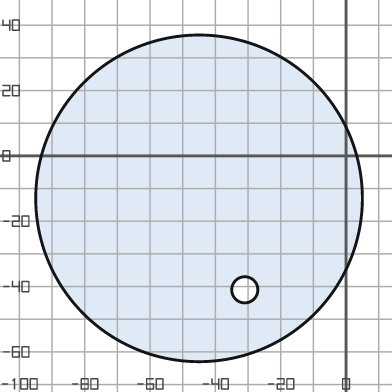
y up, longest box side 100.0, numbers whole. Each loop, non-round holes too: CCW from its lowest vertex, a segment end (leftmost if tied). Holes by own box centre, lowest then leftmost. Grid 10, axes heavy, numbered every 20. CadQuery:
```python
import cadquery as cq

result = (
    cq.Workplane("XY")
    .moveTo(-45.0, -13.0)
    .circle(50.0)
    .moveTo(-31.0, -41.0)
    .circle(4.0)
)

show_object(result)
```